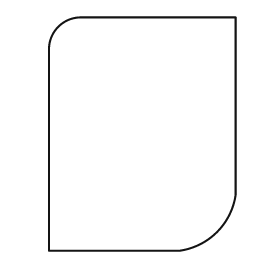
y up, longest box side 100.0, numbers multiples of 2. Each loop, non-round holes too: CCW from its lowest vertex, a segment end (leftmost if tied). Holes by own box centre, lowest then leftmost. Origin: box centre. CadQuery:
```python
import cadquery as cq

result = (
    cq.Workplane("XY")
    .moveTo(-40.0, -50.0)
    .lineTo(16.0, -50.0)
    .threePointArc((32.0, -42.0), (40.0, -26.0))
    .lineTo(40.0, 50.0)
    .lineTo(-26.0, 50.0)
    .threePointArc((-36.0, 46.0), (-40.0, 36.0))
    .close()
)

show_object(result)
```